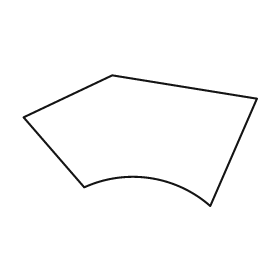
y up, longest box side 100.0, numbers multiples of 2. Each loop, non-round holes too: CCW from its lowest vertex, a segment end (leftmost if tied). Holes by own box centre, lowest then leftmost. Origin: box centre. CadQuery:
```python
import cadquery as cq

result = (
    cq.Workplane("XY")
    .moveTo(30.0, -28.0)
    .lineTo(50.0, 18.0)
    .lineTo(-12.0, 28.0)
    .lineTo(-50.0, 10.0)
    .lineTo(-24.0, -20.0)
    .threePointArc((4.0, -16.0), (30.0, -28.0))
    .close()
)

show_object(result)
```